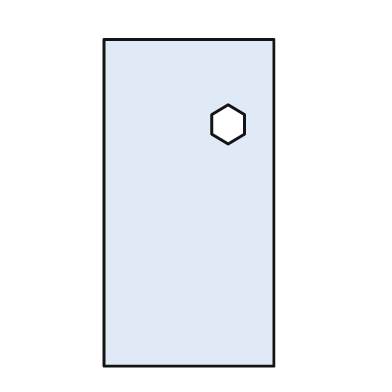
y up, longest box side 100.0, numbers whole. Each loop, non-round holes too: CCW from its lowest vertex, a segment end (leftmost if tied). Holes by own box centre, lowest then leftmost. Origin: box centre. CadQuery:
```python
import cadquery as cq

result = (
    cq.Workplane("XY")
    .moveTo(-26.0, -50.0)
    .lineTo(26.0, -50.0)
    .lineTo(26.0, 50.0)
    .lineTo(-26.0, 50.0)
    .close()
    .moveTo(12.0, 18.0)
    .lineTo(17.0, 21.0)
    .lineTo(17.0, 27.0)
    .lineTo(12.0, 30.0)
    .lineTo(7.0, 27.0)
    .lineTo(7.0, 21.0)
    .close()
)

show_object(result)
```